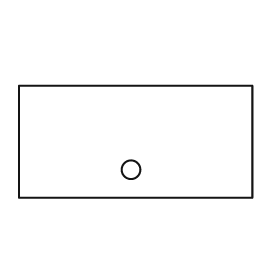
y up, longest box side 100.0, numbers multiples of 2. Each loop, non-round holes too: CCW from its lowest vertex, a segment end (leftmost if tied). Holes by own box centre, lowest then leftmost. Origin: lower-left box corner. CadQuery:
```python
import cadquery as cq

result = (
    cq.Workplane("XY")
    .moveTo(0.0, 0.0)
    .lineTo(100.0, 0.0)
    .lineTo(100.0, 48.0)
    .lineTo(0.0, 48.0)
    .close()
    .moveTo(48.0, 12.0)
    .circle(4.0)
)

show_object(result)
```